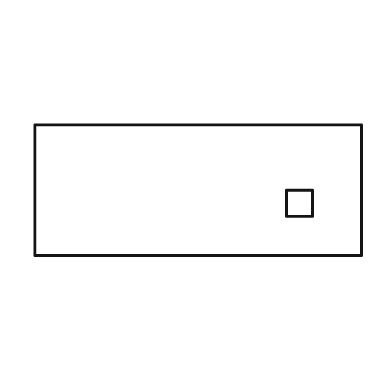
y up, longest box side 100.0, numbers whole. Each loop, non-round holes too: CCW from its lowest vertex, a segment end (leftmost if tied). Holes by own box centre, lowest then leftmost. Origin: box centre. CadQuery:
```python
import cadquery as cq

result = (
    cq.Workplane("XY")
    .moveTo(-50.0, -20.0)
    .lineTo(50.0, -20.0)
    .lineTo(50.0, 20.0)
    .lineTo(-50.0, 20.0)
    .close()
    .moveTo(27.0, -8.0)
    .lineTo(35.0, -8.0)
    .lineTo(35.0, 0.0)
    .lineTo(27.0, 0.0)
    .close()
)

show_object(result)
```